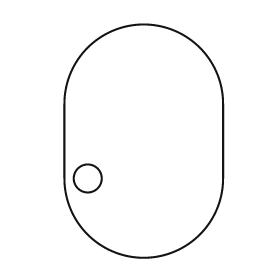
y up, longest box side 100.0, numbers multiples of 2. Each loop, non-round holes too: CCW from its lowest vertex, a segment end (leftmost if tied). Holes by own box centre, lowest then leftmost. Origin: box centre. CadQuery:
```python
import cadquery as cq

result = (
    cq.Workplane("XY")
    .moveTo(-34.0, -16.0)
    .threePointArc((0.0, -50.0), (34.0, -16.0))
    .lineTo(34.0, 16.0)
    .threePointArc((0.0, 50.0), (-34.0, 16.0))
    .close()
    .moveTo(-24.0, -16.0)
    .circle(6.0)
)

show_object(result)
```